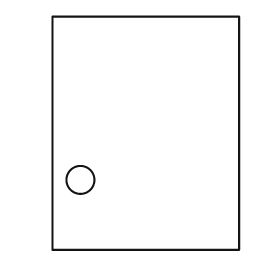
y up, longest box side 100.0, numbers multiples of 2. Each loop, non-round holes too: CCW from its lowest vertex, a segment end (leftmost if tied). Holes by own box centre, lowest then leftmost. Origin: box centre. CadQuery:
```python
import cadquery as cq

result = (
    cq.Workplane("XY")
    .moveTo(-40.0, -50.0)
    .lineTo(40.0, -50.0)
    .lineTo(40.0, 50.0)
    .lineTo(-40.0, 50.0)
    .close()
    .moveTo(-28.0, -20.0)
    .circle(6.0)
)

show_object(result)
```